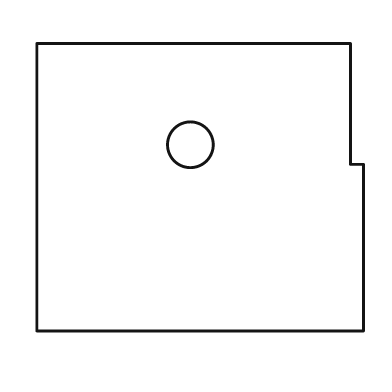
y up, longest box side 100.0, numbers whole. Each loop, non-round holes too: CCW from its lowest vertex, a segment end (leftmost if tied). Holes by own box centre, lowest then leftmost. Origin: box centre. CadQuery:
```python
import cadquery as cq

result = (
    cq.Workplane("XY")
    .moveTo(-50.0, -44.0)
    .lineTo(50.0, -44.0)
    .lineTo(50.0, 7.0)
    .lineTo(46.0, 7.0)
    .lineTo(46.0, 44.0)
    .lineTo(-50.0, 44.0)
    .close()
    .moveTo(-3.0, 13.0)
    .circle(7.0)
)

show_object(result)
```